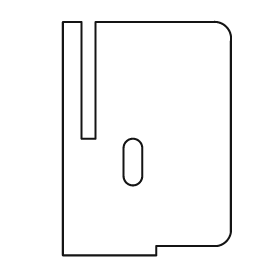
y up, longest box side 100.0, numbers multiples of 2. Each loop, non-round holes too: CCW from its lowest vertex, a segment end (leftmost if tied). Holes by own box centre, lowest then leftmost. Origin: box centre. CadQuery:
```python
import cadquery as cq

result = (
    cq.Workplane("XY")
    .moveTo(-36.0, -50.0)
    .lineTo(4.0, -50.0)
    .lineTo(4.0, -46.0)
    .lineTo(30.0, -46.0)
    .threePointArc((34.0, -44.0), (36.0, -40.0))
    .lineTo(36.0, 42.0)
    .threePointArc((34.0, 48.0), (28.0, 50.0))
    .lineTo(-22.0, 50.0)
    .lineTo(-22.0, 0.0)
    .lineTo(-28.0, 0.0)
    .lineTo(-28.0, 50.0)
    .lineTo(-36.0, 50.0)
    .close()
    .moveTo(-10.0, -16.0)
    .threePointArc((-6.0, -20.0), (-2.0, -16.0))
    .lineTo(-2.0, -4.0)
    .threePointArc((-6.0, 0.0), (-10.0, -4.0))
    .close()
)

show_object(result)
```